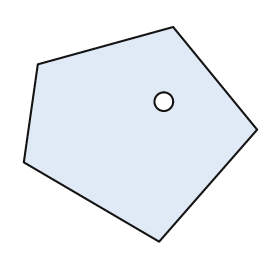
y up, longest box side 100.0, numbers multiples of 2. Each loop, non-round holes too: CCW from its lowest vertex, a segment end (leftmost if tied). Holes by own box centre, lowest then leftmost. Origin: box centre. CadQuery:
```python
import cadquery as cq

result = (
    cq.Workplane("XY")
    .moveTo(8.0, -46.0)
    .lineTo(50.0, 2.0)
    .lineTo(14.0, 46.0)
    .lineTo(-44.0, 30.0)
    .lineTo(-50.0, -12.0)
    .close()
    .moveTo(10.0, 14.0)
    .circle(4.0)
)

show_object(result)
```